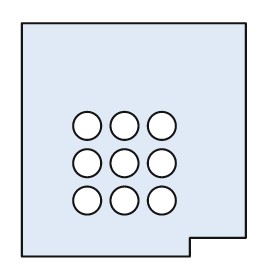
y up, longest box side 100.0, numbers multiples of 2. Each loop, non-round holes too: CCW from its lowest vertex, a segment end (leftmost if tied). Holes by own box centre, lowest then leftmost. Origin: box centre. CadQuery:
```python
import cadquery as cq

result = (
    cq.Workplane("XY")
    .moveTo(-48.0, -50.0)
    .lineTo(24.0, -50.0)
    .lineTo(24.0, -42.0)
    .lineTo(48.0, -42.0)
    .lineTo(48.0, 50.0)
    .lineTo(-48.0, 50.0)
    .close()
    .moveTo(-20.0, -26.0)
    .circle(6.0)
    .moveTo(-4.0, -26.0)
    .circle(6.0)
    .moveTo(12.0, -26.0)
    .circle(6.0)
    .moveTo(-20.0, -10.0)
    .circle(6.0)
    .moveTo(-4.0, -10.0)
    .circle(6.0)
    .moveTo(12.0, -10.0)
    .circle(6.0)
    .moveTo(-20.0, 6.0)
    .circle(6.0)
    .moveTo(-4.0, 6.0)
    .circle(6.0)
    .moveTo(12.0, 6.0)
    .circle(6.0)
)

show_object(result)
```